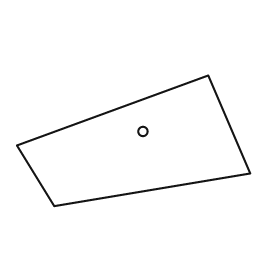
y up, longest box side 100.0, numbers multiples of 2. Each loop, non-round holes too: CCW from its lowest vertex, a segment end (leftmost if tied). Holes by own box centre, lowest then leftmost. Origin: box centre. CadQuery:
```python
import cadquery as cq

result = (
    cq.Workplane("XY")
    .moveTo(-34.0, -28.0)
    .lineTo(50.0, -14.0)
    .lineTo(32.0, 28.0)
    .lineTo(-50.0, -2.0)
    .close()
    .moveTo(4.0, 4.0)
    .circle(2.0)
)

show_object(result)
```